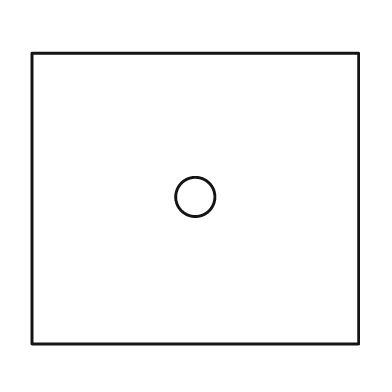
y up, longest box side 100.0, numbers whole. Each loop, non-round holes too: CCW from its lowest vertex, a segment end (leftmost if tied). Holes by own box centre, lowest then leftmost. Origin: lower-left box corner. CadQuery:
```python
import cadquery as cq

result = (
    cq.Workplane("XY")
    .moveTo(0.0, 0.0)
    .lineTo(100.0, 0.0)
    .lineTo(100.0, 89.0)
    .lineTo(0.0, 89.0)
    .close()
    .moveTo(50.0, 45.0)
    .circle(6.0)
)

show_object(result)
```